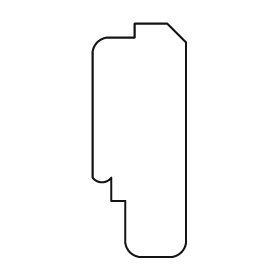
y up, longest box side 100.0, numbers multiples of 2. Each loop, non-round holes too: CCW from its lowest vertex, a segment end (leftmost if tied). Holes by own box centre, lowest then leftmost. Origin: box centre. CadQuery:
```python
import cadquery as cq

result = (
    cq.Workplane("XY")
    .moveTo(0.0, -50.0)
    .lineTo(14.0, -50.0)
    .threePointArc((18.0, -48.0), (20.0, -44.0))
    .lineTo(20.0, 42.0)
    .lineTo(12.0, 50.0)
    .lineTo(-2.0, 50.0)
    .lineTo(-2.0, 44.0)
    .lineTo(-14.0, 44.0)
    .threePointArc((-18.0, 42.0), (-20.0, 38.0))
    .lineTo(-20.0, -16.0)
    .threePointArc((-16.0, -18.0), (-12.0, -16.0))
    .lineTo(-12.0, -26.0)
    .lineTo(-6.0, -26.0)
    .lineTo(-6.0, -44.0)
    .threePointArc((-4.0, -48.0), (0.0, -50.0))
    .close()
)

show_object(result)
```